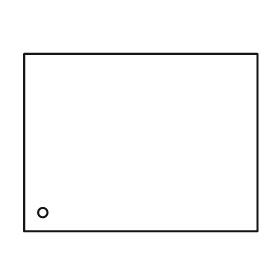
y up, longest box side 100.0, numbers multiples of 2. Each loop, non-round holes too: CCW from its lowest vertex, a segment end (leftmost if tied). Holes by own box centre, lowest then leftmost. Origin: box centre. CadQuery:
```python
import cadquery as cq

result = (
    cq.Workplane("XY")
    .moveTo(-50.0, -38.0)
    .lineTo(50.0, -38.0)
    .lineTo(50.0, 38.0)
    .lineTo(-50.0, 38.0)
    .close()
    .moveTo(-42.0, -30.0)
    .circle(2.0)
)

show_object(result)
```